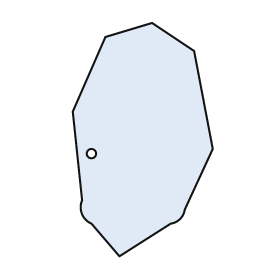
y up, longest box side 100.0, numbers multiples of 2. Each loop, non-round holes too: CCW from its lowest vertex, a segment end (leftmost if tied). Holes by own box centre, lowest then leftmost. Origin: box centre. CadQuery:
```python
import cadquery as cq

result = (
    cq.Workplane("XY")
    .moveTo(-10.0, -50.0)
    .lineTo(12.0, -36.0)
    .threePointArc((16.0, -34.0), (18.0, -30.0))
    .lineTo(30.0, -4.0)
    .lineTo(22.0, 38.0)
    .lineTo(4.0, 50.0)
    .lineTo(-16.0, 44.0)
    .lineTo(-30.0, 12.0)
    .lineTo(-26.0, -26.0)
    .threePointArc((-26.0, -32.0), (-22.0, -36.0))
    .close()
    .moveTo(-22.0, -6.0)
    .circle(2.0)
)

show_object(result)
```